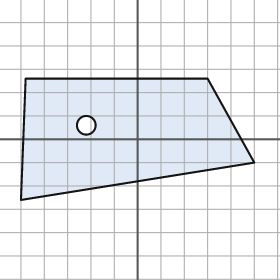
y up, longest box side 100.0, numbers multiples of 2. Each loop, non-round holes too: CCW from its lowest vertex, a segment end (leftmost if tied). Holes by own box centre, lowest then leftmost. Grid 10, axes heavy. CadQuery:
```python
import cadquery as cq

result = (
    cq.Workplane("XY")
    .moveTo(-50.0, -26.0)
    .lineTo(50.0, -10.0)
    .lineTo(30.0, 26.0)
    .lineTo(-48.0, 26.0)
    .close()
    .moveTo(-22.0, 6.0)
    .circle(4.0)
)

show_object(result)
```